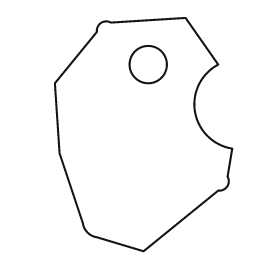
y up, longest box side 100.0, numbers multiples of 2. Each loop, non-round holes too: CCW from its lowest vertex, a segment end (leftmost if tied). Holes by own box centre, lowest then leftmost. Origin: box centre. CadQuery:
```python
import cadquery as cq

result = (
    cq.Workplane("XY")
    .moveTo(0.0, -50.0)
    .lineTo(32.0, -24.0)
    .threePointArc((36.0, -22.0), (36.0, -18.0))
    .lineTo(38.0, -6.0)
    .threePointArc((22.0, 10.0), (32.0, 30.0))
    .lineTo(18.0, 50.0)
    .lineTo(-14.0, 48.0)
    .threePointArc((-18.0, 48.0), (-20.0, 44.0))
    .lineTo(-38.0, 22.0)
    .lineTo(-36.0, -8.0)
    .lineTo(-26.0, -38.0)
    .threePointArc((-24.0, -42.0), (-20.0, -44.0))
    .close()
    .moveTo(2.0, 30.0)
    .circle(8.0)
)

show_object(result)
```